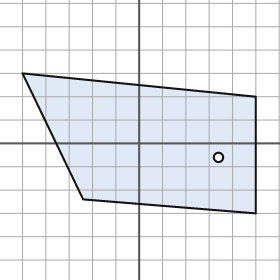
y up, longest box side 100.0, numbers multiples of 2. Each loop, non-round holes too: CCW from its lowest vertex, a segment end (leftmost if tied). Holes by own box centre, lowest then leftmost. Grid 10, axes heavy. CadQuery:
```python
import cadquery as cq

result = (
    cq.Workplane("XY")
    .moveTo(50.0, -30.0)
    .lineTo(50.0, 20.0)
    .lineTo(-50.0, 30.0)
    .lineTo(-24.0, -24.0)
    .close()
    .moveTo(34.0, -6.0)
    .circle(2.0)
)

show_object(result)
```